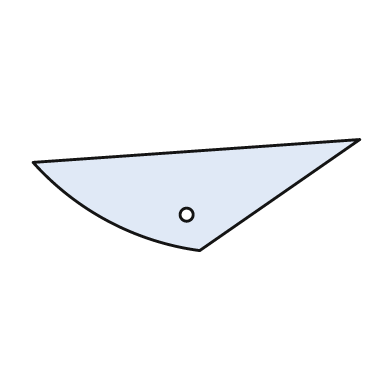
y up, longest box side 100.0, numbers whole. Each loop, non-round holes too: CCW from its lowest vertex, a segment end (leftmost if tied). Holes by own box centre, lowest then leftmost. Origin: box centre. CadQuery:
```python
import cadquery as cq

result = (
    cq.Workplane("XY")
    .moveTo(1.0, -17.0)
    .lineTo(50.0, 17.0)
    .lineTo(-50.0, 10.0)
    .threePointArc((-27.0, -8.0), (1.0, -17.0))
    .close()
    .moveTo(-3.0, -6.0)
    .circle(2.0)
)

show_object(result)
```